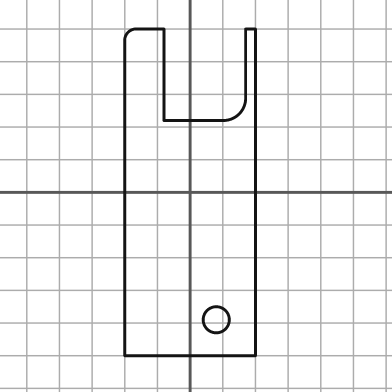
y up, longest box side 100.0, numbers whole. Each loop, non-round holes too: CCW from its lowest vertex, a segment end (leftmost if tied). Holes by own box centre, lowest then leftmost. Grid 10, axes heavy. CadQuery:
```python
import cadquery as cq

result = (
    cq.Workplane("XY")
    .moveTo(-20.0, -50.0)
    .lineTo(20.0, -50.0)
    .lineTo(20.0, 50.0)
    .lineTo(17.0, 50.0)
    .lineTo(17.0, 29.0)
    .threePointArc((15.0, 24.0), (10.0, 22.0))
    .lineTo(-8.0, 22.0)
    .lineTo(-8.0, 50.0)
    .lineTo(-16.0, 50.0)
    .threePointArc((-19.0, 49.0), (-20.0, 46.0))
    .close()
    .moveTo(8.0, -39.0)
    .circle(4.0)
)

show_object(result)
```